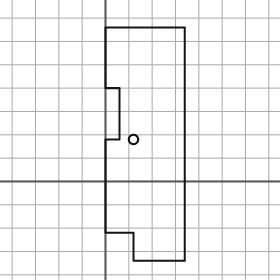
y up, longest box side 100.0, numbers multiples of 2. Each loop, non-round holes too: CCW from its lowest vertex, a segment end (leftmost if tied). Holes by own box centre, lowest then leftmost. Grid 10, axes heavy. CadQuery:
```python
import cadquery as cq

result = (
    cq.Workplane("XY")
    .moveTo(12.0, -34.0)
    .lineTo(34.0, -34.0)
    .lineTo(34.0, 66.0)
    .lineTo(0.0, 66.0)
    .lineTo(0.0, 40.0)
    .lineTo(6.0, 40.0)
    .lineTo(6.0, 18.0)
    .lineTo(0.0, 18.0)
    .lineTo(0.0, -22.0)
    .lineTo(12.0, -22.0)
    .close()
    .moveTo(12.0, 18.0)
    .circle(2.0)
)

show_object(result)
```